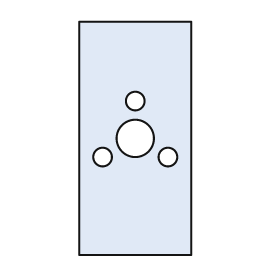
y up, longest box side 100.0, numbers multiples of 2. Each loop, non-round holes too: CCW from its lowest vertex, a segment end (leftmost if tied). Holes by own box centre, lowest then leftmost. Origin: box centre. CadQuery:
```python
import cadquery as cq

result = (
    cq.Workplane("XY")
    .moveTo(-24.0, -50.0)
    .lineTo(24.0, -50.0)
    .lineTo(24.0, 50.0)
    .lineTo(-24.0, 50.0)
    .close()
    .moveTo(-14.0, -8.0)
    .circle(4.0)
    .moveTo(14.0, -8.0)
    .circle(4.0)
    .moveTo(0.0, 0.0)
    .circle(8.0)
    .moveTo(0.0, 16.0)
    .circle(4.0)
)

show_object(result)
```